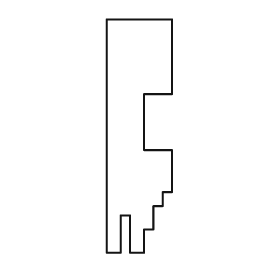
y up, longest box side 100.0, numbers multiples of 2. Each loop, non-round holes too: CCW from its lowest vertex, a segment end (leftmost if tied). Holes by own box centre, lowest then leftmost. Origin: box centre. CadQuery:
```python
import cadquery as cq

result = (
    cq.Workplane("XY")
    .moveTo(-14.0, -50.0)
    .lineTo(-8.0, -50.0)
    .lineTo(-8.0, -34.0)
    .lineTo(-4.0, -34.0)
    .lineTo(-4.0, -50.0)
    .lineTo(2.0, -50.0)
    .lineTo(2.0, -40.0)
    .lineTo(6.0, -40.0)
    .lineTo(6.0, -30.0)
    .lineTo(10.0, -30.0)
    .lineTo(10.0, -24.0)
    .lineTo(14.0, -24.0)
    .lineTo(14.0, -6.0)
    .lineTo(2.0, -6.0)
    .lineTo(2.0, 18.0)
    .lineTo(14.0, 18.0)
    .lineTo(14.0, 50.0)
    .lineTo(-14.0, 50.0)
    .close()
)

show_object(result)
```